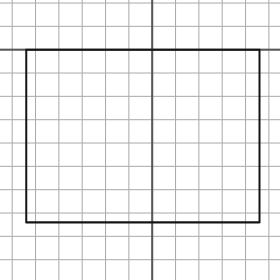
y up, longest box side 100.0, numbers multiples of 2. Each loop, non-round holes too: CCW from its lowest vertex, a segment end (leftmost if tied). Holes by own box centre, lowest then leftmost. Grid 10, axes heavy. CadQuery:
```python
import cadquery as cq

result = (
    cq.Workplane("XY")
    .moveTo(-54.0, -74.0)
    .lineTo(46.0, -74.0)
    .lineTo(46.0, 0.0)
    .lineTo(-54.0, 0.0)
    .close()
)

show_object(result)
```